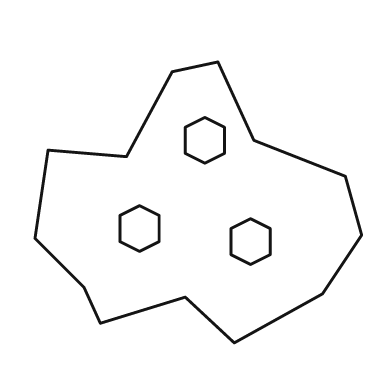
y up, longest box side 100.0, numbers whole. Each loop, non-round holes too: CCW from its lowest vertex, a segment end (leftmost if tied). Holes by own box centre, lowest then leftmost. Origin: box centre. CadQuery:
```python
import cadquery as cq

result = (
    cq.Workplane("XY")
    .moveTo(11.0, -43.0)
    .lineTo(38.0, -28.0)
    .lineTo(50.0, -10.0)
    .lineTo(45.0, 8.0)
    .lineTo(17.0, 19.0)
    .lineTo(6.0, 43.0)
    .lineTo(-8.0, 40.0)
    .lineTo(-22.0, 14.0)
    .lineTo(-46.0, 16.0)
    .lineTo(-50.0, -11.0)
    .lineTo(-35.0, -26.0)
    .lineTo(-30.0, -37.0)
    .lineTo(-4.0, -29.0)
    .close()
    .moveTo(16.0, -19.0)
    .lineTo(22.0, -16.0)
    .lineTo(22.0, -8.0)
    .lineTo(16.0, -5.0)
    .lineTo(10.0, -8.0)
    .lineTo(10.0, -16.0)
    .close()
    .moveTo(-18.0, -15.0)
    .lineTo(-12.0, -12.0)
    .lineTo(-12.0, -4.0)
    .lineTo(-18.0, -1.0)
    .lineTo(-24.0, -4.0)
    .lineTo(-24.0, -12.0)
    .close()
    .moveTo(2.0, 12.0)
    .lineTo(8.0, 15.0)
    .lineTo(8.0, 23.0)
    .lineTo(2.0, 26.0)
    .lineTo(-4.0, 23.0)
    .lineTo(-4.0, 15.0)
    .close()
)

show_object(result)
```